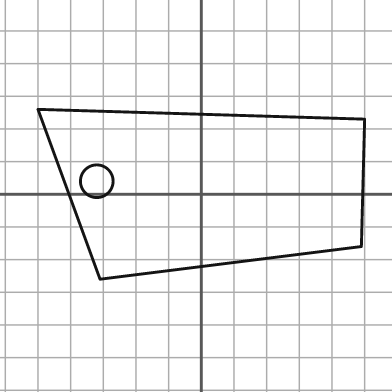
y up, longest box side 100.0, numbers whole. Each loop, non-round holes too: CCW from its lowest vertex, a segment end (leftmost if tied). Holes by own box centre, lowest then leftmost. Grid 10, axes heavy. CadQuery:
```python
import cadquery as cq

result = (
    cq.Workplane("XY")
    .moveTo(-31.0, -26.0)
    .lineTo(49.0, -16.0)
    .lineTo(50.0, 23.0)
    .lineTo(-50.0, 26.0)
    .close()
    .moveTo(-32.0, 4.0)
    .circle(5.0)
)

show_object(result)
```